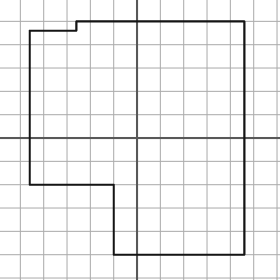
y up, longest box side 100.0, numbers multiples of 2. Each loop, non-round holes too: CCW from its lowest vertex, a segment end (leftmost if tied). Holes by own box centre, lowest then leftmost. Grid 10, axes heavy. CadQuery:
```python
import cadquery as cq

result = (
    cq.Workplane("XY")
    .moveTo(-10.0, -50.0)
    .lineTo(46.0, -50.0)
    .lineTo(46.0, 50.0)
    .lineTo(-26.0, 50.0)
    .lineTo(-26.0, 46.0)
    .lineTo(-46.0, 46.0)
    .lineTo(-46.0, -20.0)
    .lineTo(-10.0, -20.0)
    .close()
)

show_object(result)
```